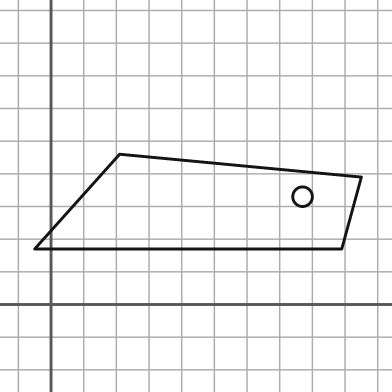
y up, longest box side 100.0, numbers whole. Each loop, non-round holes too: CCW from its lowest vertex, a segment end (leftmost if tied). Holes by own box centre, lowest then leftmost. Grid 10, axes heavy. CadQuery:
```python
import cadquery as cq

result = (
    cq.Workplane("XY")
    .moveTo(-5.0, 17.0)
    .lineTo(89.0, 17.0)
    .lineTo(95.0, 39.0)
    .lineTo(21.0, 46.0)
    .close()
    .moveTo(77.0, 33.0)
    .circle(3.0)
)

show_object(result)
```